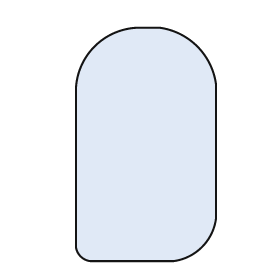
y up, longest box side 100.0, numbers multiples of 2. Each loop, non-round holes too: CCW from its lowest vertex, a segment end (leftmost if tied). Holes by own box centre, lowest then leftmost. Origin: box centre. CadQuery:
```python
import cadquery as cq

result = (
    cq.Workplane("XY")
    .moveTo(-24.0, -50.0)
    .lineTo(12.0, -50.0)
    .threePointArc((24.0, -44.0), (30.0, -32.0))
    .lineTo(30.0, 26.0)
    .threePointArc((22.0, 42.0), (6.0, 50.0))
    .lineTo(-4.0, 50.0)
    .threePointArc((-22.0, 42.0), (-30.0, 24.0))
    .lineTo(-30.0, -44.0)
    .threePointArc((-28.0, -48.0), (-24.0, -50.0))
    .close()
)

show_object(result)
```